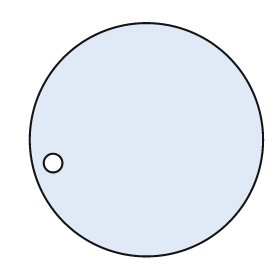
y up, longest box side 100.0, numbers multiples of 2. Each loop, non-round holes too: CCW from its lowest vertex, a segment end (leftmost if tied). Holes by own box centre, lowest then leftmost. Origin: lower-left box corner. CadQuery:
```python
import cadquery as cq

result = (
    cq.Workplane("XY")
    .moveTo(50.0, 50.0)
    .circle(50.0)
    .moveTo(10.0, 40.0)
    .circle(4.0)
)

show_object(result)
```